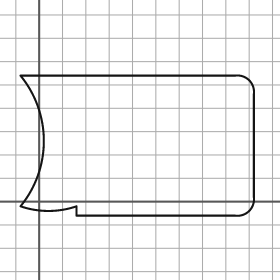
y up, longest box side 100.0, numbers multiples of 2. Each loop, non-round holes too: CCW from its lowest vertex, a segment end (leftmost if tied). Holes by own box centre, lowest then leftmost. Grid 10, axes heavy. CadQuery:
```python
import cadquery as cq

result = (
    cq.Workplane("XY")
    .moveTo(16.0, -6.0)
    .lineTo(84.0, -6.0)
    .threePointArc((90.0, -4.0), (92.0, 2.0))
    .lineTo(92.0, 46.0)
    .threePointArc((90.0, 52.0), (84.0, 54.0))
    .lineTo(-8.0, 54.0)
    .threePointArc((2.0, 26.0), (-8.0, -2.0))
    .threePointArc((4.0, -4.0), (16.0, -2.0))
    .close()
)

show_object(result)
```